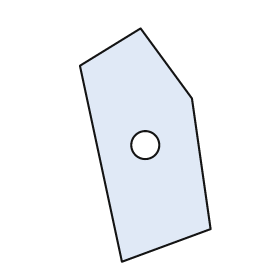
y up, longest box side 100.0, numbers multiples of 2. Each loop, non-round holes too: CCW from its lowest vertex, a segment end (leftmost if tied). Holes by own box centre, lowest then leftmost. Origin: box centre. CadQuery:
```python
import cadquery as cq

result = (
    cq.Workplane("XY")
    .moveTo(-10.0, -50.0)
    .lineTo(28.0, -36.0)
    .lineTo(20.0, 20.0)
    .lineTo(-2.0, 50.0)
    .lineTo(-28.0, 34.0)
    .close()
    .moveTo(0.0, 0.0)
    .circle(6.0)
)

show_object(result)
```